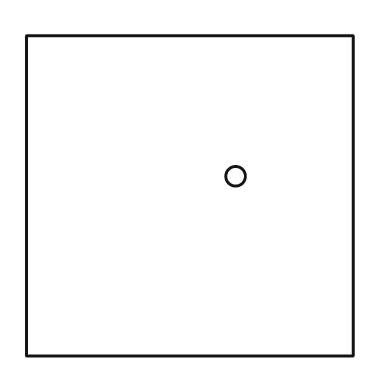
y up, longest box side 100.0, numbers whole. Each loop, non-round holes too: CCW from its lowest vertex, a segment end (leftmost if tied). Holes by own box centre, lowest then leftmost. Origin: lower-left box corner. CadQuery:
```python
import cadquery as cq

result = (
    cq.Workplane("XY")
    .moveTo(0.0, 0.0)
    .lineTo(100.0, 0.0)
    .lineTo(100.0, 98.0)
    .lineTo(0.0, 98.0)
    .close()
    .moveTo(64.0, 55.0)
    .circle(3.0)
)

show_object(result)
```